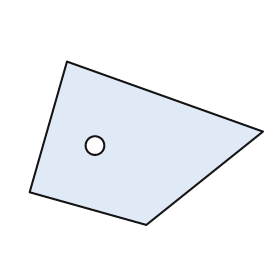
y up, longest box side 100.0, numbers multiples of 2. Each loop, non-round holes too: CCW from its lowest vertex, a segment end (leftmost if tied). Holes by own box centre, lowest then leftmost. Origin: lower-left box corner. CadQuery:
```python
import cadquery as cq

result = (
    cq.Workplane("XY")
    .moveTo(50.0, 0.0)
    .lineTo(100.0, 40.0)
    .lineTo(16.0, 70.0)
    .lineTo(0.0, 14.0)
    .close()
    .moveTo(28.0, 34.0)
    .circle(4.0)
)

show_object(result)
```